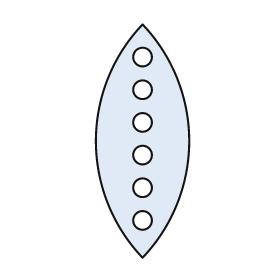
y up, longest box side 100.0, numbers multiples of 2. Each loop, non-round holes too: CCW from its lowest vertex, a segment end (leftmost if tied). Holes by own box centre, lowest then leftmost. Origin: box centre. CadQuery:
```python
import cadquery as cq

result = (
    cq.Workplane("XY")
    .moveTo(0.0, -50.0)
    .threePointArc((20.0, 0.0), (0.0, 50.0))
    .threePointArc((-20.0, 0.0), (0.0, -50.0))
    .close()
    .moveTo(0.0, -34.0)
    .circle(4.0)
    .moveTo(0.0, -20.0)
    .circle(4.0)
    .moveTo(0.0, -6.0)
    .circle(4.0)
    .moveTo(0.0, 8.0)
    .circle(4.0)
    .moveTo(0.0, 22.0)
    .circle(4.0)
    .moveTo(0.0, 36.0)
    .circle(4.0)
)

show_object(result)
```